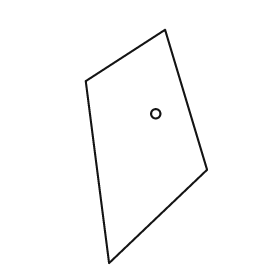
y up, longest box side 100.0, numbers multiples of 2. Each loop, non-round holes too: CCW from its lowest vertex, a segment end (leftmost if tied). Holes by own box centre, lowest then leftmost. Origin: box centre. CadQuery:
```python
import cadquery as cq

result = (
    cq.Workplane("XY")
    .moveTo(-16.0, -50.0)
    .lineTo(26.0, -10.0)
    .lineTo(8.0, 50.0)
    .lineTo(-26.0, 28.0)
    .close()
    .moveTo(4.0, 14.0)
    .circle(2.0)
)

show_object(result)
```